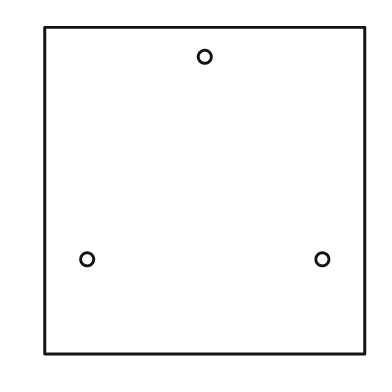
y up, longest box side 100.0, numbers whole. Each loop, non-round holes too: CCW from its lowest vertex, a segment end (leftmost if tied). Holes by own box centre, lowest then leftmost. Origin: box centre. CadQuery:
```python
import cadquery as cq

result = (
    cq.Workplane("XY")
    .moveTo(-49.0, -50.0)
    .lineTo(49.0, -50.0)
    .lineTo(49.0, 50.0)
    .lineTo(-49.0, 50.0)
    .close()
    .moveTo(-36.0, -21.0)
    .circle(2.0)
    .moveTo(36.0, -21.0)
    .circle(2.0)
    .moveTo(0.0, 41.0)
    .circle(2.0)
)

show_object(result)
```